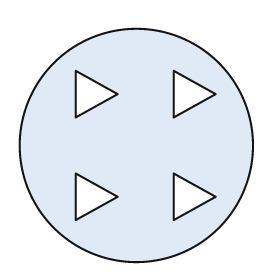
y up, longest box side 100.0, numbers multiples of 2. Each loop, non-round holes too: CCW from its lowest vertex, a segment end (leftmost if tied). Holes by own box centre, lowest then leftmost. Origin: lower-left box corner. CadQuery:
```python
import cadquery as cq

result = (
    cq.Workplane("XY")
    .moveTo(50.0, 50.0)
    .circle(50.0)
    .moveTo(24.0, 18.0)
    .lineTo(42.0, 28.0)
    .lineTo(24.0, 38.0)
    .close()
    .moveTo(66.0, 18.0)
    .lineTo(84.0, 28.0)
    .lineTo(66.0, 38.0)
    .close()
    .moveTo(24.0, 62.0)
    .lineTo(42.0, 72.0)
    .lineTo(24.0, 82.0)
    .close()
    .moveTo(66.0, 62.0)
    .lineTo(84.0, 72.0)
    .lineTo(66.0, 82.0)
    .close()
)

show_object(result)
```